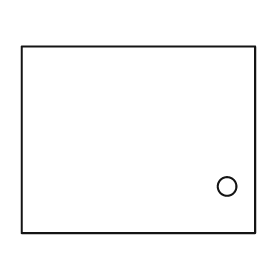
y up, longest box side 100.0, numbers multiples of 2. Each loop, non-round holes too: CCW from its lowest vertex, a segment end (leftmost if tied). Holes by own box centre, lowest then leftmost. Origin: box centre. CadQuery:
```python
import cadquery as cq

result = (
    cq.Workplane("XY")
    .moveTo(-50.0, -40.0)
    .lineTo(50.0, -40.0)
    .lineTo(50.0, 40.0)
    .lineTo(-50.0, 40.0)
    .close()
    .moveTo(38.0, -20.0)
    .circle(4.0)
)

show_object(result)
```